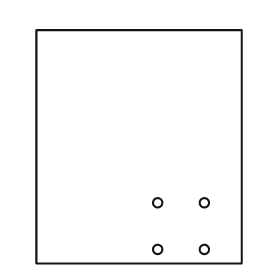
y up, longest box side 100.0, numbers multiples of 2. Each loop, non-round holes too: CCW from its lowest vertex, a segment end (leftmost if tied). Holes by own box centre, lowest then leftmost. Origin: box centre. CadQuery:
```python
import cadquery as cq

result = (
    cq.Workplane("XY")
    .moveTo(-44.0, -50.0)
    .lineTo(44.0, -50.0)
    .lineTo(44.0, 50.0)
    .lineTo(-44.0, 50.0)
    .close()
    .moveTo(8.0, -44.0)
    .circle(2.0)
    .moveTo(28.0, -44.0)
    .circle(2.0)
    .moveTo(8.0, -24.0)
    .circle(2.0)
    .moveTo(28.0, -24.0)
    .circle(2.0)
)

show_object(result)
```